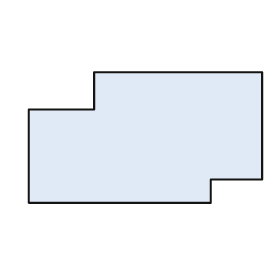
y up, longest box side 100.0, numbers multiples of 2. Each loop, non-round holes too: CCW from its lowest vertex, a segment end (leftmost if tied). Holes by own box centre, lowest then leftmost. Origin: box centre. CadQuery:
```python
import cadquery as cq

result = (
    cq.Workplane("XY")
    .moveTo(-50.0, -28.0)
    .lineTo(28.0, -28.0)
    .lineTo(28.0, -18.0)
    .lineTo(50.0, -18.0)
    .lineTo(50.0, 28.0)
    .lineTo(-22.0, 28.0)
    .lineTo(-22.0, 12.0)
    .lineTo(-50.0, 12.0)
    .close()
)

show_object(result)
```